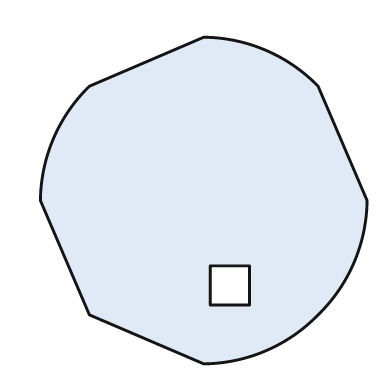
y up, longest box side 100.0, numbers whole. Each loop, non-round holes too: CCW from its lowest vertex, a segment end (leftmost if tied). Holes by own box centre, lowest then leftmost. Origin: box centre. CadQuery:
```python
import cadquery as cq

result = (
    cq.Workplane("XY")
    .moveTo(0.0, -50.0)
    .threePointArc((19.0, -46.0), (35.0, -35.0))
    .threePointArc((46.0, -19.0), (50.0, 0.0))
    .lineTo(35.0, 35.0)
    .threePointArc((19.0, 46.0), (0.0, 50.0))
    .lineTo(-35.0, 35.0)
    .threePointArc((-46.0, 19.0), (-50.0, 0.0))
    .lineTo(-35.0, -35.0)
    .close()
    .moveTo(2.0, -32.0)
    .lineTo(14.0, -32.0)
    .lineTo(14.0, -20.0)
    .lineTo(2.0, -20.0)
    .close()
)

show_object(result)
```